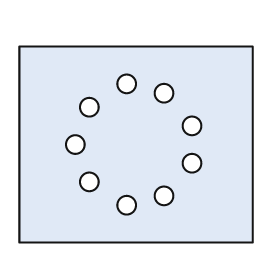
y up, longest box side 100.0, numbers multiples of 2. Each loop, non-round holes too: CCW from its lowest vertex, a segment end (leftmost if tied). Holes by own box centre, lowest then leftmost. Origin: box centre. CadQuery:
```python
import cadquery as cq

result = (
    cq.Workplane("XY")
    .moveTo(-50.0, -42.0)
    .lineTo(50.0, -42.0)
    .lineTo(50.0, 42.0)
    .lineTo(-50.0, 42.0)
    .close()
    .moveTo(-4.0, -26.0)
    .circle(4.0)
    .moveTo(12.0, -22.0)
    .circle(4.0)
    .moveTo(-20.0, -16.0)
    .circle(4.0)
    .moveTo(24.0, -8.0)
    .circle(4.0)
    .moveTo(-26.0, 0.0)
    .circle(4.0)
    .moveTo(24.0, 8.0)
    .circle(4.0)
    .moveTo(-20.0, 16.0)
    .circle(4.0)
    .moveTo(12.0, 22.0)
    .circle(4.0)
    .moveTo(-4.0, 26.0)
    .circle(4.0)
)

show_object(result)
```